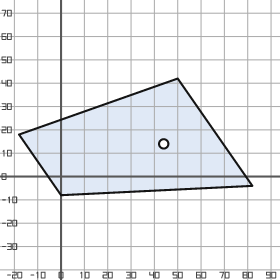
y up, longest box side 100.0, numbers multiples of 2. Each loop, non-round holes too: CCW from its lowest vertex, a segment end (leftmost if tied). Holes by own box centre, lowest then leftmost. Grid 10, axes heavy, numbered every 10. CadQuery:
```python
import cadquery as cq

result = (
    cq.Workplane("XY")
    .moveTo(0.0, -8.0)
    .lineTo(82.0, -4.0)
    .lineTo(50.0, 42.0)
    .lineTo(-18.0, 18.0)
    .close()
    .moveTo(44.0, 14.0)
    .circle(2.0)
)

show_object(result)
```